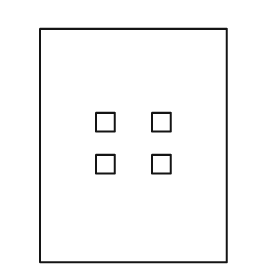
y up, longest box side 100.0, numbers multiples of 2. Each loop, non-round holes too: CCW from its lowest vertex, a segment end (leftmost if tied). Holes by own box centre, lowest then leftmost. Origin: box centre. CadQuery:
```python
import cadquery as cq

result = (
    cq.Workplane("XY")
    .moveTo(-40.0, -50.0)
    .lineTo(40.0, -50.0)
    .lineTo(40.0, 50.0)
    .lineTo(-40.0, 50.0)
    .close()
    .moveTo(-16.0, -12.0)
    .lineTo(-8.0, -12.0)
    .lineTo(-8.0, -4.0)
    .lineTo(-16.0, -4.0)
    .close()
    .moveTo(8.0, -12.0)
    .lineTo(16.0, -12.0)
    .lineTo(16.0, -4.0)
    .lineTo(8.0, -4.0)
    .close()
    .moveTo(-16.0, 6.0)
    .lineTo(-8.0, 6.0)
    .lineTo(-8.0, 14.0)
    .lineTo(-16.0, 14.0)
    .close()
    .moveTo(8.0, 6.0)
    .lineTo(16.0, 6.0)
    .lineTo(16.0, 14.0)
    .lineTo(8.0, 14.0)
    .close()
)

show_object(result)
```